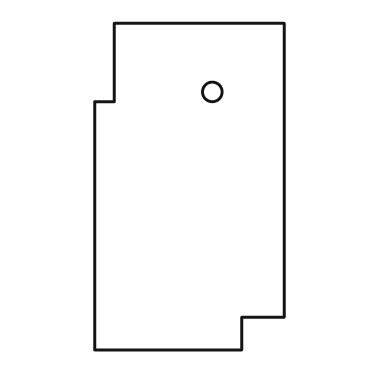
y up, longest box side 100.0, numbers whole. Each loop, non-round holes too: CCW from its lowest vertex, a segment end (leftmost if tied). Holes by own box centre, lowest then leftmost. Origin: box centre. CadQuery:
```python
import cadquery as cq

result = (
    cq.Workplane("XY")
    .moveTo(-29.0, -50.0)
    .lineTo(16.0, -50.0)
    .lineTo(16.0, -40.0)
    .lineTo(29.0, -40.0)
    .lineTo(29.0, 50.0)
    .lineTo(-23.0, 50.0)
    .lineTo(-23.0, 26.0)
    .lineTo(-29.0, 26.0)
    .close()
    .moveTo(7.0, 29.0)
    .circle(3.0)
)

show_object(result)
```